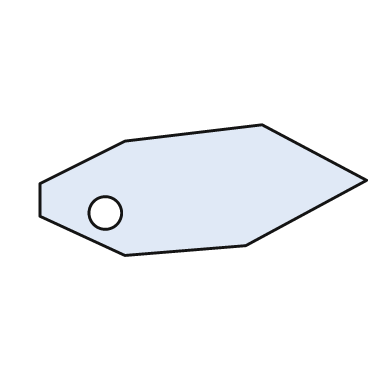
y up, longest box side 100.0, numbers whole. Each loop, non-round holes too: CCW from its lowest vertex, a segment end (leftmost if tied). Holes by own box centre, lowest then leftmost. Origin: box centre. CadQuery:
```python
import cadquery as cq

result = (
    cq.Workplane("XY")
    .moveTo(-24.0, -20.0)
    .lineTo(13.0, -17.0)
    .lineTo(50.0, 3.0)
    .lineTo(18.0, 20.0)
    .lineTo(-24.0, 15.0)
    .lineTo(-50.0, 2.0)
    .lineTo(-50.0, -8.0)
    .close()
    .moveTo(-30.0, -7.0)
    .circle(5.0)
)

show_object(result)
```